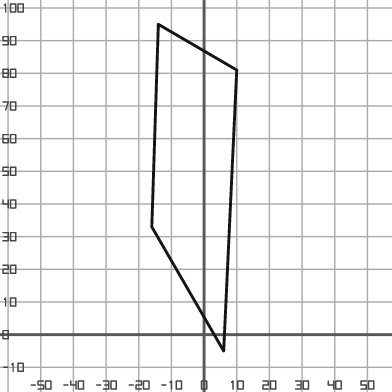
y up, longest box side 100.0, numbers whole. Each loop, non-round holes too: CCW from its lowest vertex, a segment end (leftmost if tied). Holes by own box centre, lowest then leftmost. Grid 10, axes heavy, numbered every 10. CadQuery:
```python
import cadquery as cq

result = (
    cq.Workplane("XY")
    .moveTo(6.0, -5.0)
    .lineTo(10.0, 81.0)
    .lineTo(-14.0, 95.0)
    .lineTo(-16.0, 33.0)
    .close()
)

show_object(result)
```